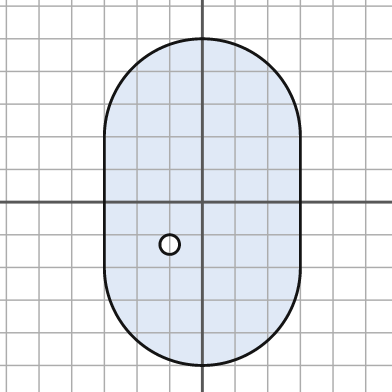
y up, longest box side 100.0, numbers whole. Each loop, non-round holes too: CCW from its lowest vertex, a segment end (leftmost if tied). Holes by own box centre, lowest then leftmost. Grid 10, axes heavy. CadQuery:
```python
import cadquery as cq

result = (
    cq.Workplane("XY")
    .moveTo(-30.0, -20.0)
    .threePointArc((0.0, -50.0), (30.0, -20.0))
    .lineTo(30.0, 20.0)
    .threePointArc((0.0, 50.0), (-30.0, 20.0))
    .close()
    .moveTo(-10.0, -13.0)
    .circle(3.0)
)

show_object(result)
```